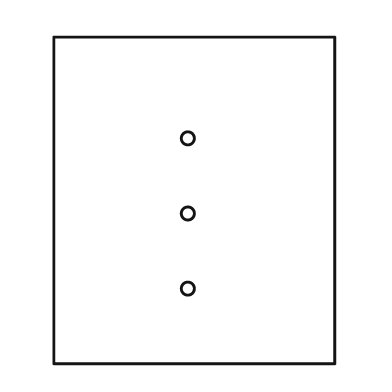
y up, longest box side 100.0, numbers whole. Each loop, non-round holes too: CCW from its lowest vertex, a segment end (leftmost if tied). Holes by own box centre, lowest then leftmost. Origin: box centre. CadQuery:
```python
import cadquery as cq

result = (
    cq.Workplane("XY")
    .moveTo(-43.0, -50.0)
    .lineTo(43.0, -50.0)
    .lineTo(43.0, 50.0)
    .lineTo(-43.0, 50.0)
    .close()
    .moveTo(-2.0, -27.0)
    .circle(2.0)
    .moveTo(-2.0, -4.0)
    .circle(2.0)
    .moveTo(-2.0, 19.0)
    .circle(2.0)
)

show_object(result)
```